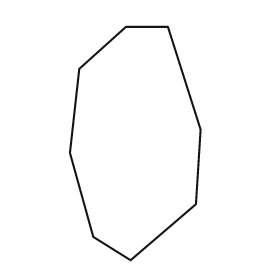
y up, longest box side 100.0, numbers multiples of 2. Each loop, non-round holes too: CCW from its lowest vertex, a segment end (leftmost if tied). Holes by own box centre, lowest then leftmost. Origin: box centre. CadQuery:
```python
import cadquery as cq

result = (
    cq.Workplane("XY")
    .moveTo(-2.0, -50.0)
    .lineTo(26.0, -26.0)
    .lineTo(28.0, 6.0)
    .lineTo(14.0, 50.0)
    .lineTo(-4.0, 50.0)
    .lineTo(-24.0, 32.0)
    .lineTo(-28.0, -4.0)
    .lineTo(-18.0, -40.0)
    .close()
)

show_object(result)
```